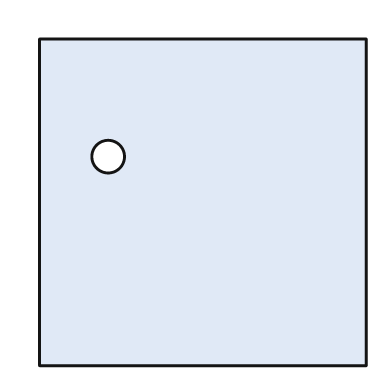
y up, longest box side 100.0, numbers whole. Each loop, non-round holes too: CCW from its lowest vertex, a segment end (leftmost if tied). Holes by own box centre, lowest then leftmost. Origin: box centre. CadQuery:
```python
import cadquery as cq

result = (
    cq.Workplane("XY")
    .moveTo(-50.0, -50.0)
    .lineTo(50.0, -50.0)
    .lineTo(50.0, 50.0)
    .lineTo(-50.0, 50.0)
    .close()
    .moveTo(-29.0, 14.0)
    .circle(5.0)
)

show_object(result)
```